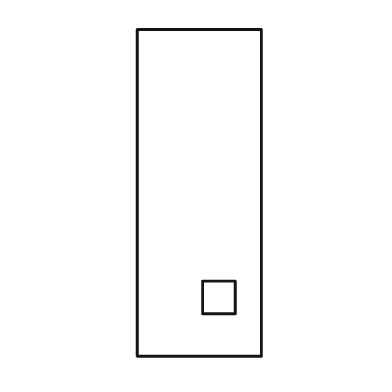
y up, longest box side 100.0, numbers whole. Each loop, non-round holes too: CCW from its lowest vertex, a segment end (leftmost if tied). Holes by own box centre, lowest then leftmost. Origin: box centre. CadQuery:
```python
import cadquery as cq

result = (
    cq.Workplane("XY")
    .moveTo(-19.0, -50.0)
    .lineTo(19.0, -50.0)
    .lineTo(19.0, 50.0)
    .lineTo(-19.0, 50.0)
    .close()
    .moveTo(1.0, -37.0)
    .lineTo(11.0, -37.0)
    .lineTo(11.0, -27.0)
    .lineTo(1.0, -27.0)
    .close()
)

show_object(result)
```